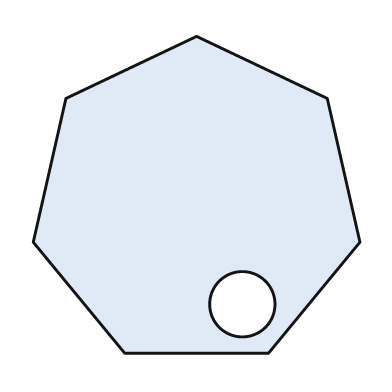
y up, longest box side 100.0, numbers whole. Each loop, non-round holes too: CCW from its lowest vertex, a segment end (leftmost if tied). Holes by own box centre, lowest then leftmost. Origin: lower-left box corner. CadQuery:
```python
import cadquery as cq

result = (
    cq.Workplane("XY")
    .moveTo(28.0, 0.0)
    .lineTo(72.0, 0.0)
    .lineTo(100.0, 34.0)
    .lineTo(90.0, 78.0)
    .lineTo(50.0, 97.0)
    .lineTo(10.0, 78.0)
    .lineTo(0.0, 34.0)
    .close()
    .moveTo(64.0, 15.0)
    .circle(10.0)
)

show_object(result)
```